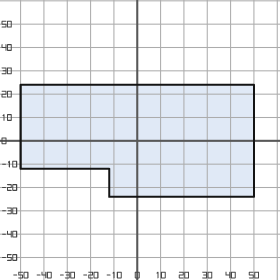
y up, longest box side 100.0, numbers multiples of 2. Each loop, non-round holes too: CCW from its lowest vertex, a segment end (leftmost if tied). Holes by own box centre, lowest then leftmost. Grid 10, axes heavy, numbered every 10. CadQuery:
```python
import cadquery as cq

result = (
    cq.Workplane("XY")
    .moveTo(-12.0, -24.0)
    .lineTo(50.0, -24.0)
    .lineTo(50.0, 24.0)
    .lineTo(-50.0, 24.0)
    .lineTo(-50.0, -12.0)
    .lineTo(-12.0, -12.0)
    .close()
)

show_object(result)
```